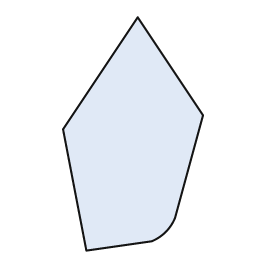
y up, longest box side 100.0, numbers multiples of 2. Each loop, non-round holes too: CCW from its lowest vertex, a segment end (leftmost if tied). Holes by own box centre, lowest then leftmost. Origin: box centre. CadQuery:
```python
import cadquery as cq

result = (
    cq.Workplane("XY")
    .moveTo(-20.0, -50.0)
    .lineTo(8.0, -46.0)
    .threePointArc((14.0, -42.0), (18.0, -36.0))
    .lineTo(30.0, 8.0)
    .lineTo(2.0, 50.0)
    .lineTo(-30.0, 2.0)
    .close()
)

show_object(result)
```